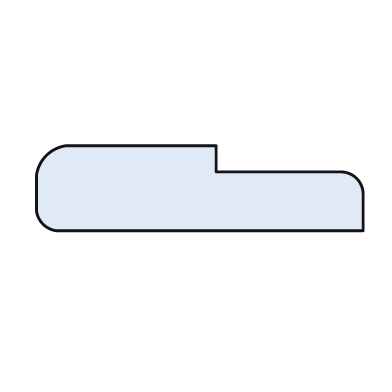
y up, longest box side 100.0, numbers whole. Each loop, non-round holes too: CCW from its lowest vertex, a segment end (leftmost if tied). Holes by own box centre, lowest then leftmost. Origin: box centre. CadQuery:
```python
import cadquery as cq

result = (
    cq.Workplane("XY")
    .moveTo(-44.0, -13.0)
    .lineTo(50.0, -13.0)
    .lineTo(50.0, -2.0)
    .threePointArc((48.0, 3.0), (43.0, 5.0))
    .lineTo(5.0, 5.0)
    .lineTo(5.0, 13.0)
    .lineTo(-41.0, 13.0)
    .threePointArc((-47.0, 10.0), (-50.0, 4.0))
    .lineTo(-50.0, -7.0)
    .threePointArc((-48.0, -11.0), (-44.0, -13.0))
    .close()
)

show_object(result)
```